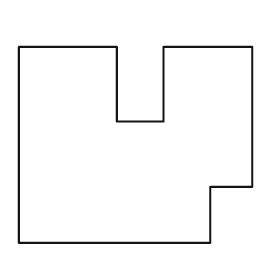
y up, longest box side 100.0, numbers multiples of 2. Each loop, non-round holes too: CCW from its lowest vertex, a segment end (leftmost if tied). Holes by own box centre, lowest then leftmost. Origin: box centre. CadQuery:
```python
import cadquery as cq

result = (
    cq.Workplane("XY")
    .moveTo(-50.0, -42.0)
    .lineTo(32.0, -42.0)
    .lineTo(32.0, -18.0)
    .lineTo(50.0, -18.0)
    .lineTo(50.0, 42.0)
    .lineTo(12.0, 42.0)
    .lineTo(12.0, 10.0)
    .lineTo(-8.0, 10.0)
    .lineTo(-8.0, 42.0)
    .lineTo(-50.0, 42.0)
    .close()
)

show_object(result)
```